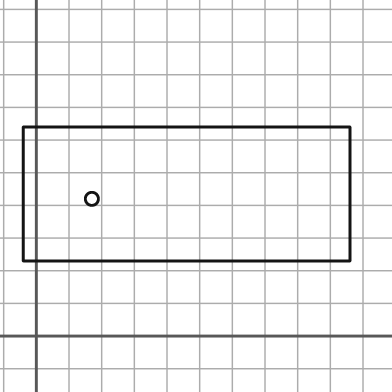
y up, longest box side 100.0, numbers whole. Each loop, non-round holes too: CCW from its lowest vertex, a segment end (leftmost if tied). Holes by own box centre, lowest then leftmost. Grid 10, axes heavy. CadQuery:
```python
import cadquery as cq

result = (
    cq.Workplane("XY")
    .moveTo(-4.0, 23.0)
    .lineTo(96.0, 23.0)
    .lineTo(96.0, 64.0)
    .lineTo(-4.0, 64.0)
    .close()
    .moveTo(17.0, 42.0)
    .circle(2.0)
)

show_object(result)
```